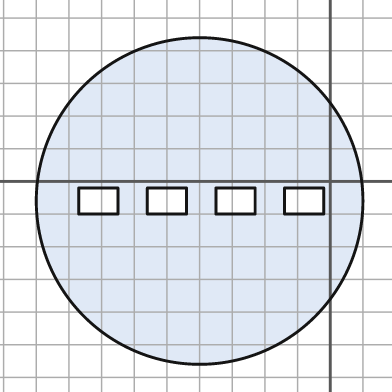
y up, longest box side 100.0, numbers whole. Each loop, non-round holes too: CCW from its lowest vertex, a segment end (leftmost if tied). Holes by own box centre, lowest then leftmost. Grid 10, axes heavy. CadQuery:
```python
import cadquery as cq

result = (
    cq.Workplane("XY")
    .moveTo(-40.0, -6.0)
    .circle(50.0)
    .moveTo(-77.0, -10.0)
    .lineTo(-65.0, -10.0)
    .lineTo(-65.0, -2.0)
    .lineTo(-77.0, -2.0)
    .close()
    .moveTo(-56.0, -10.0)
    .lineTo(-44.0, -10.0)
    .lineTo(-44.0, -2.0)
    .lineTo(-56.0, -2.0)
    .close()
    .moveTo(-35.0, -10.0)
    .lineTo(-23.0, -10.0)
    .lineTo(-23.0, -2.0)
    .lineTo(-35.0, -2.0)
    .close()
    .moveTo(-14.0, -10.0)
    .lineTo(-2.0, -10.0)
    .lineTo(-2.0, -2.0)
    .lineTo(-14.0, -2.0)
    .close()
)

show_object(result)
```